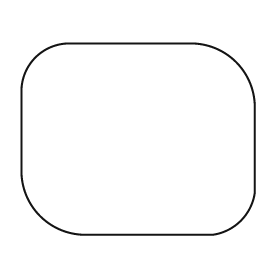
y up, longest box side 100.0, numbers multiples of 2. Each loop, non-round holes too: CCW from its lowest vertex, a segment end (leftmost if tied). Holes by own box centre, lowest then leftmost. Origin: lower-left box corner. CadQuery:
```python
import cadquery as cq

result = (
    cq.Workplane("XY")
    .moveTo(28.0, 0.0)
    .lineTo(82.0, 0.0)
    .threePointArc((94.0, 6.0), (100.0, 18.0))
    .lineTo(100.0, 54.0)
    .threePointArc((92.0, 74.0), (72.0, 82.0))
    .lineTo(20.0, 82.0)
    .threePointArc((6.0, 76.0), (0.0, 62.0))
    .lineTo(0.0, 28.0)
    .threePointArc((8.0, 8.0), (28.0, 0.0))
    .close()
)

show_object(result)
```